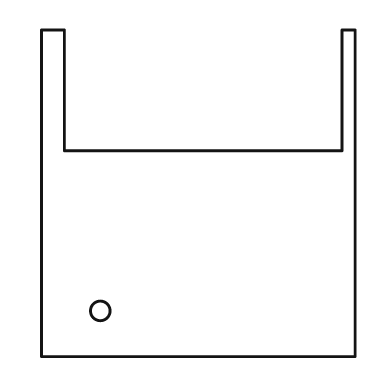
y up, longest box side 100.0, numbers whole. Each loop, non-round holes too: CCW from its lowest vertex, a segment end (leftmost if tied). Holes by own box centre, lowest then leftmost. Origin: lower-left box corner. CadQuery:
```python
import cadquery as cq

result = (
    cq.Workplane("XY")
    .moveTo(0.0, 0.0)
    .lineTo(96.0, 0.0)
    .lineTo(96.0, 100.0)
    .lineTo(92.0, 100.0)
    .lineTo(92.0, 63.0)
    .lineTo(7.0, 63.0)
    .lineTo(7.0, 100.0)
    .lineTo(0.0, 100.0)
    .close()
    .moveTo(18.0, 14.0)
    .circle(3.0)
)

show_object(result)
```